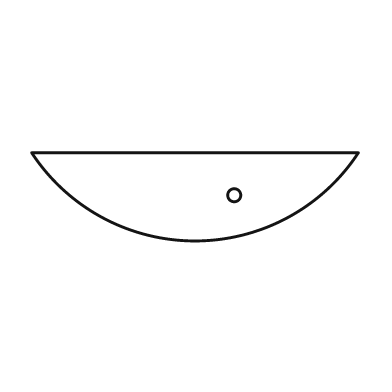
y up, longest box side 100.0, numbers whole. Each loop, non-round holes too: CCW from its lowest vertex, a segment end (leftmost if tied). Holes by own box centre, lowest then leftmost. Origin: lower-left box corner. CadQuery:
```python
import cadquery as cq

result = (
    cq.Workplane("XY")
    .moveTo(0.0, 27.0)
    .threePointArc((50.0, 0.0), (100.0, 27.0))
    .close()
    .moveTo(62.0, 14.0)
    .circle(2.0)
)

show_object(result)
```